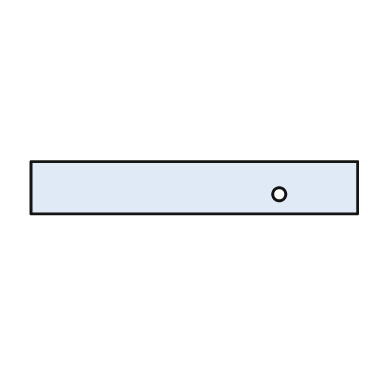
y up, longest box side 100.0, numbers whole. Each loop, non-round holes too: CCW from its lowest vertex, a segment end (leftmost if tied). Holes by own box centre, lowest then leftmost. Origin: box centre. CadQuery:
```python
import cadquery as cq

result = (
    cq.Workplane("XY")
    .moveTo(-50.0, -8.0)
    .lineTo(50.0, -8.0)
    .lineTo(50.0, 8.0)
    .lineTo(-50.0, 8.0)
    .close()
    .moveTo(26.0, -2.0)
    .circle(2.0)
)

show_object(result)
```